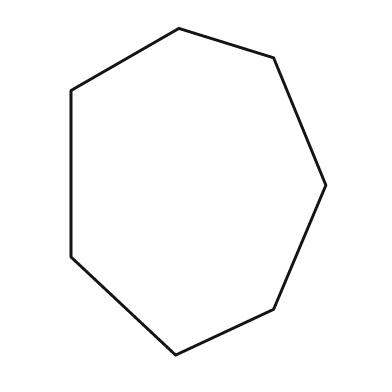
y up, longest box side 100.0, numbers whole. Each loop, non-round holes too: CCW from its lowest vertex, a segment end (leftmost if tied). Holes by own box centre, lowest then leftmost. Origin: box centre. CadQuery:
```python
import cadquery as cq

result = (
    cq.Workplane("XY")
    .moveTo(-7.0, -50.0)
    .lineTo(23.0, -36.0)
    .lineTo(39.0, 2.0)
    .lineTo(23.0, 41.0)
    .lineTo(-6.0, 50.0)
    .lineTo(-39.0, 31.0)
    .lineTo(-39.0, -20.0)
    .close()
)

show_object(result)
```